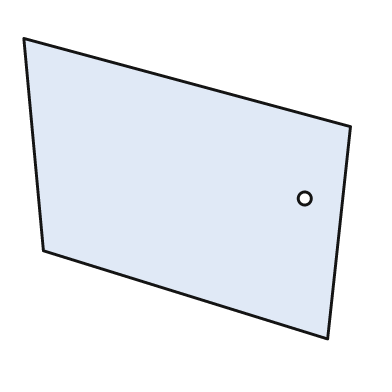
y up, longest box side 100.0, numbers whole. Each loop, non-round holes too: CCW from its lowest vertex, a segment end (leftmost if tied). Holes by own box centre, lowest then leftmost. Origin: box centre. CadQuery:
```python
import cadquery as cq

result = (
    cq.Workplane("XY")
    .moveTo(43.0, -46.0)
    .lineTo(50.0, 19.0)
    .lineTo(-50.0, 46.0)
    .lineTo(-44.0, -19.0)
    .close()
    .moveTo(36.0, -3.0)
    .circle(2.0)
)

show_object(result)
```